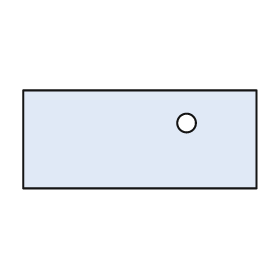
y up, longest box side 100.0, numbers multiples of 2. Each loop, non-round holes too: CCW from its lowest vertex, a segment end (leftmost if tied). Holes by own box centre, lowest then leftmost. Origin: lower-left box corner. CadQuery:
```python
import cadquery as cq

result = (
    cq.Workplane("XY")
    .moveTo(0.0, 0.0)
    .lineTo(100.0, 0.0)
    .lineTo(100.0, 42.0)
    .lineTo(0.0, 42.0)
    .close()
    .moveTo(70.0, 28.0)
    .circle(4.0)
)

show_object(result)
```